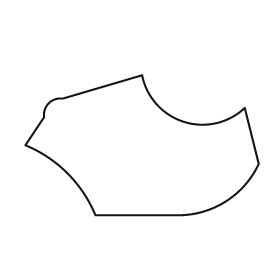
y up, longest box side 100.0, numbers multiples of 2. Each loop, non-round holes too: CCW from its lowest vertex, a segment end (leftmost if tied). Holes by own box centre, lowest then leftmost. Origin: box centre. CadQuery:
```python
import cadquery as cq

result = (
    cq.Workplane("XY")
    .moveTo(-20.0, -30.0)
    .lineTo(16.0, -30.0)
    .threePointArc((36.0, -24.0), (50.0, -8.0))
    .lineTo(44.0, 16.0)
    .threePointArc((18.0, 10.0), (0.0, 30.0))
    .lineTo(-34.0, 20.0)
    .threePointArc((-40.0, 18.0), (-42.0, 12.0))
    .lineTo(-50.0, 0.0)
    .threePointArc((-32.0, -12.0), (-20.0, -30.0))
    .close()
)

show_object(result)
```